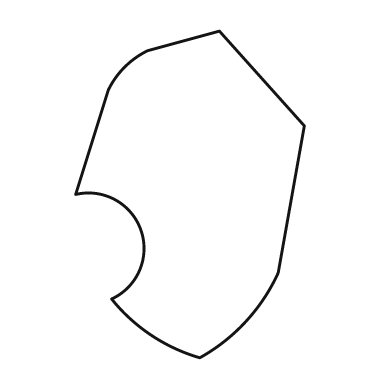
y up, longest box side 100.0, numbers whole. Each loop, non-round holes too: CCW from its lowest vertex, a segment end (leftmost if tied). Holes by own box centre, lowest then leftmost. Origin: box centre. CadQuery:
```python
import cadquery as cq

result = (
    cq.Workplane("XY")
    .moveTo(3.0, -50.0)
    .threePointArc((17.0, -39.0), (27.0, -24.0))
    .lineTo(35.0, 21.0)
    .lineTo(9.0, 50.0)
    .lineTo(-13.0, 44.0)
    .threePointArc((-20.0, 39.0), (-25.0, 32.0))
    .lineTo(-35.0, 0.0)
    .threePointArc((-15.0, -11.0), (-24.0, -32.0))
    .threePointArc((-12.0, -43.0), (3.0, -50.0))
    .close()
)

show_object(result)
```